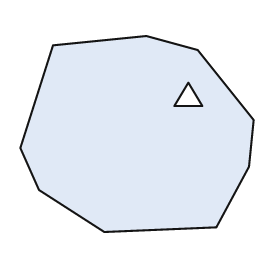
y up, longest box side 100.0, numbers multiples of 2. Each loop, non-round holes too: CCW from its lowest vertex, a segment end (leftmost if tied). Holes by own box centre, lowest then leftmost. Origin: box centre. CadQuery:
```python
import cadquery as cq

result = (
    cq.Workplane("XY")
    .moveTo(-14.0, -42.0)
    .lineTo(34.0, -40.0)
    .lineTo(48.0, -14.0)
    .lineTo(50.0, 6.0)
    .lineTo(26.0, 36.0)
    .lineTo(4.0, 42.0)
    .lineTo(-36.0, 38.0)
    .lineTo(-50.0, -6.0)
    .lineTo(-42.0, -24.0)
    .close()
    .moveTo(16.0, 12.0)
    .lineTo(28.0, 12.0)
    .lineTo(22.0, 22.0)
    .close()
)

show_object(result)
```